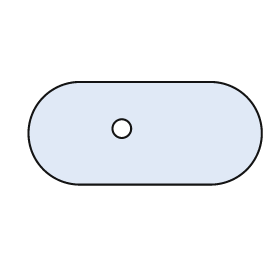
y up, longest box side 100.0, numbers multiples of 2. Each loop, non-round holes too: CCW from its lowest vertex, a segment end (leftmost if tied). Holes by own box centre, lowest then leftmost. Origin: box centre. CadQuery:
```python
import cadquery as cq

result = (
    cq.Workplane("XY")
    .moveTo(-28.0, -22.0)
    .lineTo(28.0, -22.0)
    .threePointArc((50.0, 0.0), (28.0, 22.0))
    .lineTo(-28.0, 22.0)
    .threePointArc((-50.0, 0.0), (-28.0, -22.0))
    .close()
    .moveTo(-10.0, 2.0)
    .circle(4.0)
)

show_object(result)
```